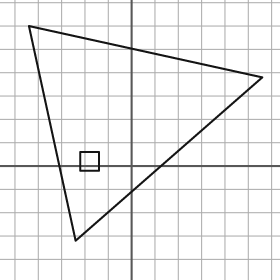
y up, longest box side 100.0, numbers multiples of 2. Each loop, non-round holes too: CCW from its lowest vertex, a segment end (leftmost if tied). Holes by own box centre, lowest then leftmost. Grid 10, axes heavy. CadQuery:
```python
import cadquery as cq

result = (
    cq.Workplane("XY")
    .moveTo(-24.0, -32.0)
    .lineTo(56.0, 38.0)
    .lineTo(-44.0, 60.0)
    .close()
    .moveTo(-22.0, -2.0)
    .lineTo(-14.0, -2.0)
    .lineTo(-14.0, 6.0)
    .lineTo(-22.0, 6.0)
    .close()
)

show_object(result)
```